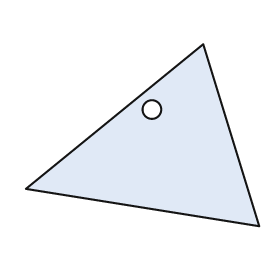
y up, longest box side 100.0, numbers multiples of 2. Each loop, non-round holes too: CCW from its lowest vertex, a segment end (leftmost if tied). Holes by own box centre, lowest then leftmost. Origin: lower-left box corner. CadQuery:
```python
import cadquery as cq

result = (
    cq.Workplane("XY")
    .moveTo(100.0, 0.0)
    .lineTo(76.0, 78.0)
    .lineTo(0.0, 16.0)
    .close()
    .moveTo(54.0, 50.0)
    .circle(4.0)
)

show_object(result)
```